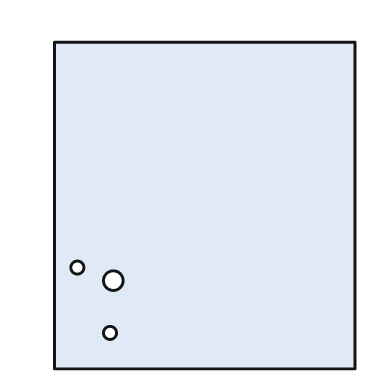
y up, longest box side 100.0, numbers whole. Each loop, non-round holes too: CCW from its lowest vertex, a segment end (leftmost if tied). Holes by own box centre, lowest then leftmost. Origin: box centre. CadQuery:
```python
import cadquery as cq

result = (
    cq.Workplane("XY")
    .moveTo(-46.0, -50.0)
    .lineTo(46.0, -50.0)
    .lineTo(46.0, 50.0)
    .lineTo(-46.0, 50.0)
    .close()
    .moveTo(-29.0, -39.0)
    .circle(2.0)
    .moveTo(-28.0, -23.0)
    .circle(3.0)
    .moveTo(-39.0, -19.0)
    .circle(2.0)
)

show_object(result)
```